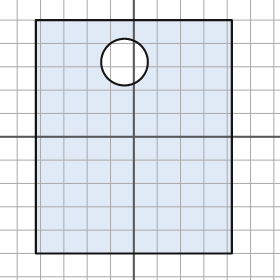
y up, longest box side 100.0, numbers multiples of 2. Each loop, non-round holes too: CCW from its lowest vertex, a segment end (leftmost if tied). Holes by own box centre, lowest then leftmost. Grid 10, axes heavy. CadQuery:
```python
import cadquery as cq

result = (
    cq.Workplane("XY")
    .moveTo(-42.0, -50.0)
    .lineTo(42.0, -50.0)
    .lineTo(42.0, 50.0)
    .lineTo(-42.0, 50.0)
    .close()
    .moveTo(-4.0, 32.0)
    .circle(10.0)
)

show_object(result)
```